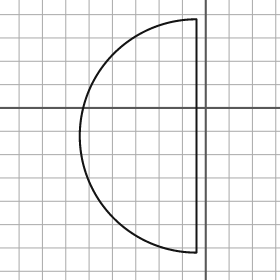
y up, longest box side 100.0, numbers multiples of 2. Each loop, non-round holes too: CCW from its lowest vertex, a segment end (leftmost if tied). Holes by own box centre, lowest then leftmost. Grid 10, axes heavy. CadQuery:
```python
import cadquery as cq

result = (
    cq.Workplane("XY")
    .moveTo(-4.0, -62.0)
    .lineTo(-4.0, 38.0)
    .threePointArc((-54.0, -12.0), (-4.0, -62.0))
    .close()
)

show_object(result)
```